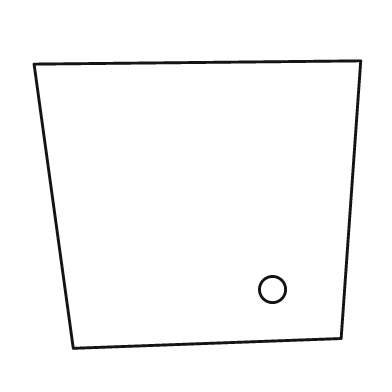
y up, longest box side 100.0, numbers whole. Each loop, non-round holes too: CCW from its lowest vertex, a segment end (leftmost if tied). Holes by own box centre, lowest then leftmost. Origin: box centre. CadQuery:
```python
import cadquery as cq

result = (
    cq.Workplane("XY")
    .moveTo(-38.0, -44.0)
    .lineTo(44.0, -41.0)
    .lineTo(50.0, 44.0)
    .lineTo(-50.0, 43.0)
    .close()
    .moveTo(23.0, -26.0)
    .circle(4.0)
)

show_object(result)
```